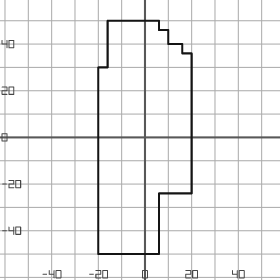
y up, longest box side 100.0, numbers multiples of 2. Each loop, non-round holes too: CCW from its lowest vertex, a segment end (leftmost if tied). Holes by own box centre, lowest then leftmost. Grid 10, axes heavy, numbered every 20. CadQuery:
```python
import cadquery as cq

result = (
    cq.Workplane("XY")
    .moveTo(-20.0, -50.0)
    .lineTo(6.0, -50.0)
    .lineTo(6.0, -24.0)
    .lineTo(20.0, -24.0)
    .lineTo(20.0, 36.0)
    .lineTo(16.0, 36.0)
    .lineTo(16.0, 40.0)
    .lineTo(10.0, 40.0)
    .lineTo(10.0, 46.0)
    .lineTo(6.0, 46.0)
    .lineTo(6.0, 50.0)
    .lineTo(-16.0, 50.0)
    .lineTo(-16.0, 30.0)
    .lineTo(-20.0, 30.0)
    .close()
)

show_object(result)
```